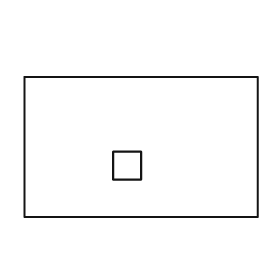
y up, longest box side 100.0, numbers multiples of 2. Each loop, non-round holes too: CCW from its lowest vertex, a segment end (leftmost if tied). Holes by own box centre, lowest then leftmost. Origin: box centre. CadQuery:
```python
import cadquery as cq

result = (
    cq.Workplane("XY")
    .moveTo(-50.0, -30.0)
    .lineTo(50.0, -30.0)
    .lineTo(50.0, 30.0)
    .lineTo(-50.0, 30.0)
    .close()
    .moveTo(-12.0, -14.0)
    .lineTo(0.0, -14.0)
    .lineTo(0.0, -2.0)
    .lineTo(-12.0, -2.0)
    .close()
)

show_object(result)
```